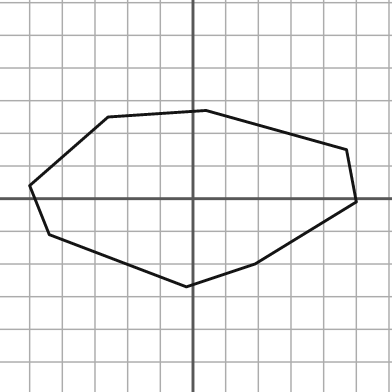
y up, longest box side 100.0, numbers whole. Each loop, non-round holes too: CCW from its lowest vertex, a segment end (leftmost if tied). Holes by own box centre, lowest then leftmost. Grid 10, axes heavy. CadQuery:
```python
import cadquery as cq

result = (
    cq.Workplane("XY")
    .moveTo(-2.0, -27.0)
    .lineTo(19.0, -20.0)
    .lineTo(50.0, -1.0)
    .lineTo(47.0, 15.0)
    .lineTo(4.0, 27.0)
    .lineTo(-26.0, 25.0)
    .lineTo(-50.0, 4.0)
    .lineTo(-44.0, -11.0)
    .close()
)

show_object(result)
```